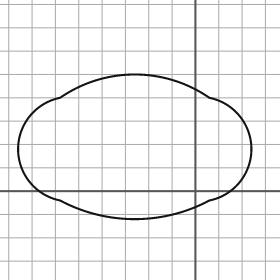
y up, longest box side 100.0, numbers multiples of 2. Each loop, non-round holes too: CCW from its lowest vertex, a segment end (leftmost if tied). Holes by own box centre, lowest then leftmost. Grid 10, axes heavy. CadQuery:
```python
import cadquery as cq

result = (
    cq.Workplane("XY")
    .moveTo(-58.0, -4.0)
    .threePointArc((-26.0, -12.0), (6.0, -4.0))
    .threePointArc((24.0, 18.0), (6.0, 40.0))
    .threePointArc((-26.0, 50.0), (-58.0, 40.0))
    .threePointArc((-76.0, 18.0), (-58.0, -4.0))
    .close()
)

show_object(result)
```